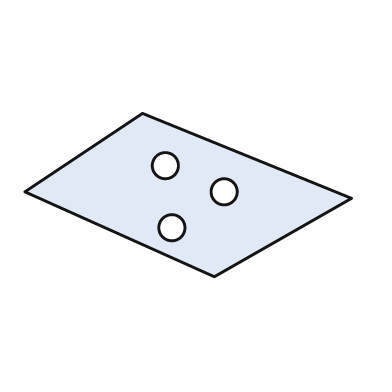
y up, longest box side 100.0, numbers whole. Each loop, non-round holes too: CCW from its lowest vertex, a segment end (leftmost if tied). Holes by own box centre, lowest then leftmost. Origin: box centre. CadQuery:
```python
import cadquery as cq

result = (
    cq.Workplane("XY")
    .moveTo(8.0, -25.0)
    .lineTo(50.0, -1.0)
    .lineTo(-14.0, 25.0)
    .lineTo(-50.0, 1.0)
    .close()
    .moveTo(-5.0, -10.0)
    .circle(4.0)
    .moveTo(11.0, 1.0)
    .circle(4.0)
    .moveTo(-7.0, 9.0)
    .circle(4.0)
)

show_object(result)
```